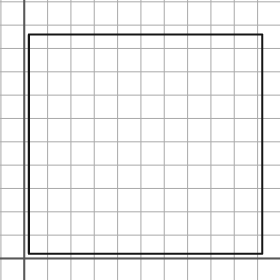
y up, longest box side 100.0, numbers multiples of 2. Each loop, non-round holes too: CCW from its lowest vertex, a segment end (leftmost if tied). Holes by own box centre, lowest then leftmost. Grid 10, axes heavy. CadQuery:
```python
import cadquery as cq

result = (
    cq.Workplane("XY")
    .moveTo(2.0, 2.0)
    .lineTo(102.0, 2.0)
    .lineTo(102.0, 96.0)
    .lineTo(2.0, 96.0)
    .close()
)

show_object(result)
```